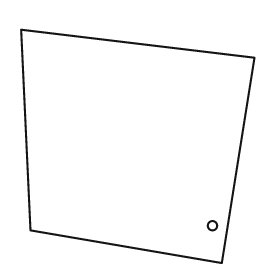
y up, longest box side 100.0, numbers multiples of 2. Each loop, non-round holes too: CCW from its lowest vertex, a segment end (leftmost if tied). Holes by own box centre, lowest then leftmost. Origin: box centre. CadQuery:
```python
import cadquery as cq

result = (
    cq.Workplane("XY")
    .moveTo(36.0, -50.0)
    .lineTo(50.0, 38.0)
    .lineTo(-50.0, 50.0)
    .lineTo(-46.0, -36.0)
    .close()
    .moveTo(32.0, -34.0)
    .circle(2.0)
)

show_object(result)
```